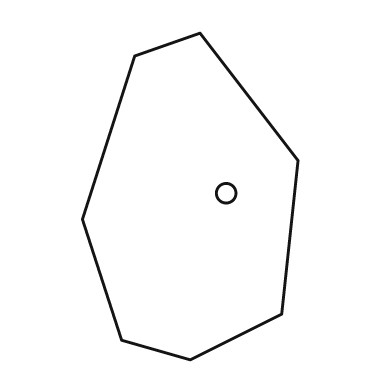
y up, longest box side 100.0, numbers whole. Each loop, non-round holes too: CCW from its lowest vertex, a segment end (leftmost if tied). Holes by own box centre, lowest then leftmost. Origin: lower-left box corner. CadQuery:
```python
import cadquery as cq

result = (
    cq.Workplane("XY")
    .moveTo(33.0, 0.0)
    .lineTo(61.0, 14.0)
    .lineTo(66.0, 61.0)
    .lineTo(36.0, 100.0)
    .lineTo(16.0, 93.0)
    .lineTo(0.0, 43.0)
    .lineTo(12.0, 6.0)
    .close()
    .moveTo(44.0, 51.0)
    .circle(3.0)
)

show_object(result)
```